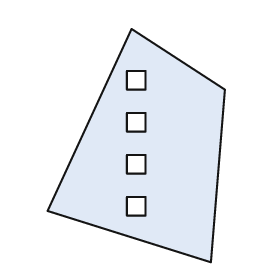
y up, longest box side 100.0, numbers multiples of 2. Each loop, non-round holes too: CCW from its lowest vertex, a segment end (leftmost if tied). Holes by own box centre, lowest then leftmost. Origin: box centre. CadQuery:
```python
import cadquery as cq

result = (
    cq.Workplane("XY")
    .moveTo(32.0, -50.0)
    .lineTo(38.0, 24.0)
    .lineTo(-2.0, 50.0)
    .lineTo(-38.0, -28.0)
    .close()
    .moveTo(-4.0, -30.0)
    .lineTo(4.0, -30.0)
    .lineTo(4.0, -22.0)
    .lineTo(-4.0, -22.0)
    .close()
    .moveTo(-4.0, -12.0)
    .lineTo(4.0, -12.0)
    .lineTo(4.0, -4.0)
    .lineTo(-4.0, -4.0)
    .close()
    .moveTo(-4.0, 6.0)
    .lineTo(4.0, 6.0)
    .lineTo(4.0, 14.0)
    .lineTo(-4.0, 14.0)
    .close()
    .moveTo(-4.0, 24.0)
    .lineTo(4.0, 24.0)
    .lineTo(4.0, 32.0)
    .lineTo(-4.0, 32.0)
    .close()
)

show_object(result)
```